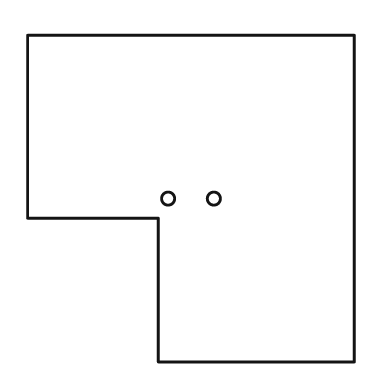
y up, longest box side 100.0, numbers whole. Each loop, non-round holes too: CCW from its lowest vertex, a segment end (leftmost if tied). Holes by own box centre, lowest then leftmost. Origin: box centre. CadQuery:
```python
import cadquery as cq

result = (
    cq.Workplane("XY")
    .moveTo(-10.0, -50.0)
    .lineTo(50.0, -50.0)
    .lineTo(50.0, 50.0)
    .lineTo(-50.0, 50.0)
    .lineTo(-50.0, -6.0)
    .lineTo(-10.0, -6.0)
    .close()
    .moveTo(-7.0, 0.0)
    .circle(2.0)
    .moveTo(7.0, 0.0)
    .circle(2.0)
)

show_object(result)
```